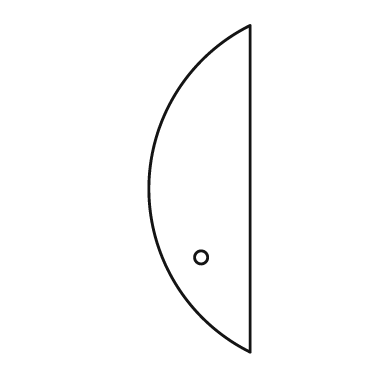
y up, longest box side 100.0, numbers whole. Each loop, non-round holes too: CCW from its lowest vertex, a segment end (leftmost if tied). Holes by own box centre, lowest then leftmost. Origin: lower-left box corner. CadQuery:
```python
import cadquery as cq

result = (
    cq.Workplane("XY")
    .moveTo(31.0, 0.0)
    .lineTo(31.0, 100.0)
    .threePointArc((0.0, 50.0), (31.0, 0.0))
    .close()
    .moveTo(16.0, 29.0)
    .circle(2.0)
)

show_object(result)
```